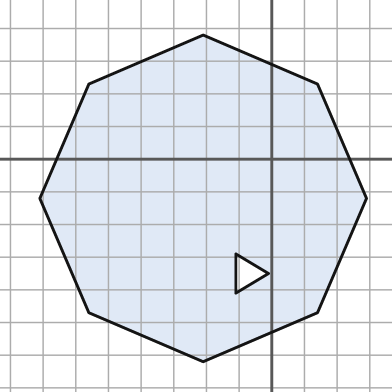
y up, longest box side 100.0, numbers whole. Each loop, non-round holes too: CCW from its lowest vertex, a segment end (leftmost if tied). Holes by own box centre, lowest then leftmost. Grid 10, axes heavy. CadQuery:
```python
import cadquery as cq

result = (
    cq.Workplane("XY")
    .moveTo(-21.0, -62.0)
    .lineTo(14.0, -47.0)
    .lineTo(29.0, -12.0)
    .lineTo(14.0, 23.0)
    .lineTo(-21.0, 38.0)
    .lineTo(-56.0, 23.0)
    .lineTo(-71.0, -12.0)
    .lineTo(-56.0, -47.0)
    .close()
    .moveTo(-11.0, -41.0)
    .lineTo(-1.0, -35.0)
    .lineTo(-11.0, -29.0)
    .close()
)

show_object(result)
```